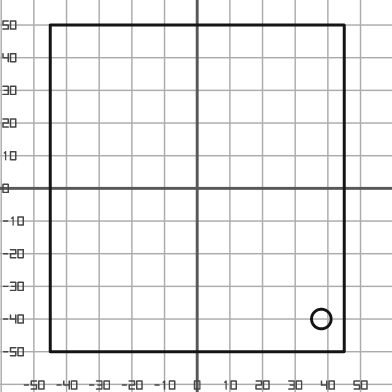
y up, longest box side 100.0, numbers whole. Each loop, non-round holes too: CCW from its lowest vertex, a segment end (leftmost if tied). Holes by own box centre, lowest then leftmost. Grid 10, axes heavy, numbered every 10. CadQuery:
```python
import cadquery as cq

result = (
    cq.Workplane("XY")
    .moveTo(-45.0, -50.0)
    .lineTo(45.0, -50.0)
    .lineTo(45.0, 50.0)
    .lineTo(-45.0, 50.0)
    .close()
    .moveTo(38.0, -40.0)
    .circle(3.0)
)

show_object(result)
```